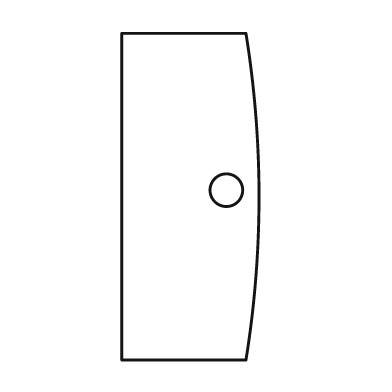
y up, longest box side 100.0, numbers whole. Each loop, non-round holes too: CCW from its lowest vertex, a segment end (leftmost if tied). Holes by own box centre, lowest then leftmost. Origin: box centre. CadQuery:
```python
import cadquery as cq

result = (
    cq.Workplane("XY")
    .moveTo(-21.0, -50.0)
    .lineTo(17.0, -50.0)
    .threePointArc((21.0, 0.0), (17.0, 50.0))
    .lineTo(-21.0, 50.0)
    .close()
    .moveTo(11.0, 2.0)
    .circle(5.0)
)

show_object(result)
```